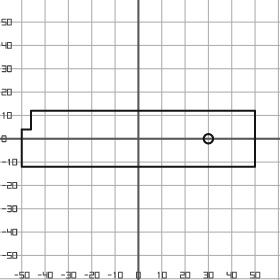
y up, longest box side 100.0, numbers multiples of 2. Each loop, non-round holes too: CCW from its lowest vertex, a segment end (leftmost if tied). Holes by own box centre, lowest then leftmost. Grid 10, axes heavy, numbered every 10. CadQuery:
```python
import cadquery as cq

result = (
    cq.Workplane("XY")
    .moveTo(-50.0, -12.0)
    .lineTo(50.0, -12.0)
    .lineTo(50.0, 12.0)
    .lineTo(-46.0, 12.0)
    .lineTo(-46.0, 4.0)
    .lineTo(-50.0, 4.0)
    .close()
    .moveTo(30.0, 0.0)
    .circle(2.0)
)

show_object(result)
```